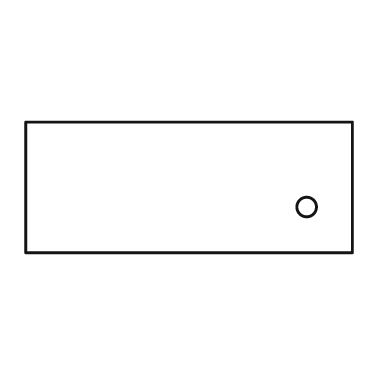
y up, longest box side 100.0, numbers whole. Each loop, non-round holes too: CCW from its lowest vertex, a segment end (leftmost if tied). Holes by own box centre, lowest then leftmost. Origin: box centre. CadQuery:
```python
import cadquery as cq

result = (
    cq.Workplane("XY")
    .moveTo(-50.0, -20.0)
    .lineTo(50.0, -20.0)
    .lineTo(50.0, 20.0)
    .lineTo(-50.0, 20.0)
    .close()
    .moveTo(36.0, -6.0)
    .circle(3.0)
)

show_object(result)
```